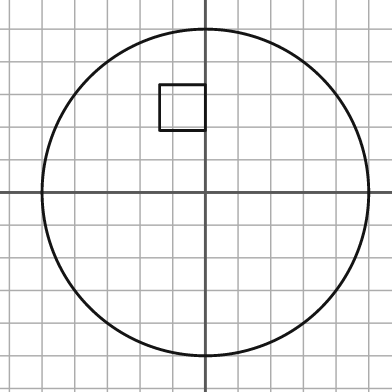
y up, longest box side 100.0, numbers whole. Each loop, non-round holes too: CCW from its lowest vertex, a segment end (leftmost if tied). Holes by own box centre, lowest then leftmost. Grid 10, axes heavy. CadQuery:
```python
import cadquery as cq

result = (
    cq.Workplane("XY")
    .moveTo(0.0, 0.0)
    .circle(50.0)
    .moveTo(-14.0, 19.0)
    .lineTo(0.0, 19.0)
    .lineTo(0.0, 33.0)
    .lineTo(-14.0, 33.0)
    .close()
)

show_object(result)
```